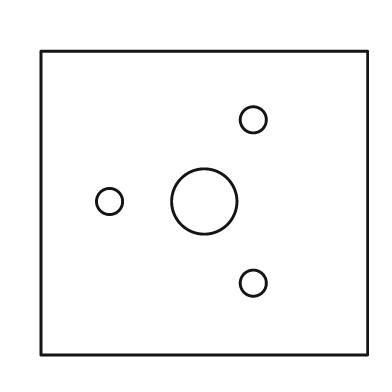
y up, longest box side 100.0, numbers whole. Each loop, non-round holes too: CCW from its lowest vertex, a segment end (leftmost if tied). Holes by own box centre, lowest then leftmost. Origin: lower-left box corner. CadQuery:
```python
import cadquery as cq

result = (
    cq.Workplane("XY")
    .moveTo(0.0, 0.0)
    .lineTo(100.0, 0.0)
    .lineTo(100.0, 93.0)
    .lineTo(0.0, 93.0)
    .close()
    .moveTo(65.0, 22.0)
    .circle(4.0)
    .moveTo(21.0, 47.0)
    .circle(4.0)
    .moveTo(50.0, 47.0)
    .circle(10.0)
    .moveTo(65.0, 72.0)
    .circle(4.0)
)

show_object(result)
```